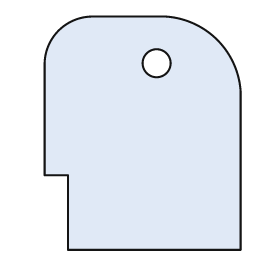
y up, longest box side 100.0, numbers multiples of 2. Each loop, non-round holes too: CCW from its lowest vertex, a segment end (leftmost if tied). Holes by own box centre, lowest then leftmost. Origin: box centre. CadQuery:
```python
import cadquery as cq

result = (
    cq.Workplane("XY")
    .moveTo(-32.0, -50.0)
    .lineTo(42.0, -50.0)
    .lineTo(42.0, 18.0)
    .threePointArc((32.0, 40.0), (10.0, 50.0))
    .lineTo(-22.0, 50.0)
    .threePointArc((-36.0, 44.0), (-42.0, 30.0))
    .lineTo(-42.0, -18.0)
    .lineTo(-32.0, -18.0)
    .close()
    .moveTo(6.0, 30.0)
    .circle(6.0)
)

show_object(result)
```